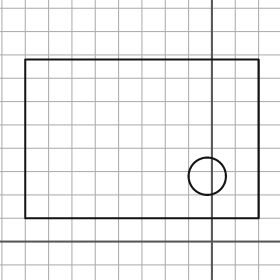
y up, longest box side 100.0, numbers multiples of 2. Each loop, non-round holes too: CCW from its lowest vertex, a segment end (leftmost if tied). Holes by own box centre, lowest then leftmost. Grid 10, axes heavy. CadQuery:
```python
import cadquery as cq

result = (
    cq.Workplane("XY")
    .moveTo(-80.0, 10.0)
    .lineTo(20.0, 10.0)
    .lineTo(20.0, 78.0)
    .lineTo(-80.0, 78.0)
    .close()
    .moveTo(-2.0, 28.0)
    .circle(8.0)
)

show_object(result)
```